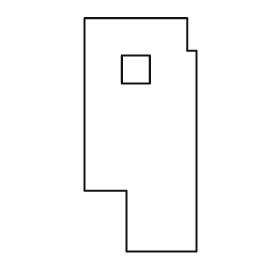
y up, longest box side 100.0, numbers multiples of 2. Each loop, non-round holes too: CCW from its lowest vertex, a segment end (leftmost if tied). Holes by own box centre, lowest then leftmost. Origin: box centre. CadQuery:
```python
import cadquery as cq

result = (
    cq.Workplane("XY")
    .moveTo(-6.0, -50.0)
    .lineTo(24.0, -50.0)
    .lineTo(24.0, 36.0)
    .lineTo(20.0, 36.0)
    .lineTo(20.0, 50.0)
    .lineTo(-24.0, 50.0)
    .lineTo(-24.0, -24.0)
    .lineTo(-6.0, -24.0)
    .close()
    .moveTo(-8.0, 22.0)
    .lineTo(4.0, 22.0)
    .lineTo(4.0, 34.0)
    .lineTo(-8.0, 34.0)
    .close()
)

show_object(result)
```